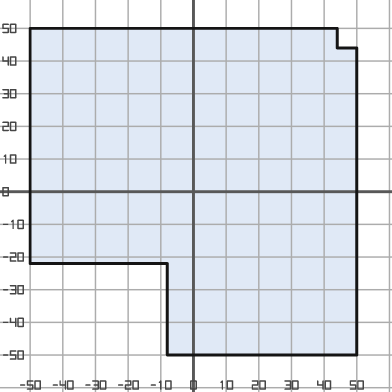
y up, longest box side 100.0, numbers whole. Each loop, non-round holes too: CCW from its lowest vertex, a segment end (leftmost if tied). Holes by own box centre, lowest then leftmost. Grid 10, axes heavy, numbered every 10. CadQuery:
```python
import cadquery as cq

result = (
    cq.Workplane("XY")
    .moveTo(-8.0, -50.0)
    .lineTo(50.0, -50.0)
    .lineTo(50.0, 44.0)
    .lineTo(44.0, 44.0)
    .lineTo(44.0, 50.0)
    .lineTo(-50.0, 50.0)
    .lineTo(-50.0, -22.0)
    .lineTo(-8.0, -22.0)
    .close()
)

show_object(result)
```